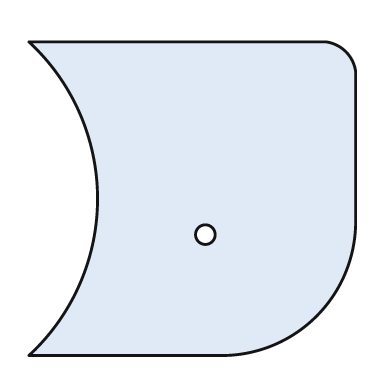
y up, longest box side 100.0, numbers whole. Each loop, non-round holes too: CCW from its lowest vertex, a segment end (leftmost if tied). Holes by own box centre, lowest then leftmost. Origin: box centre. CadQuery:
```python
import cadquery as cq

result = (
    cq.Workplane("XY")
    .moveTo(-50.0, -48.0)
    .lineTo(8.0, -48.0)
    .threePointArc((38.0, -36.0), (50.0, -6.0))
    .lineTo(50.0, 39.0)
    .threePointArc((47.0, 45.0), (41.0, 48.0))
    .lineTo(-50.0, 48.0)
    .threePointArc((-29.0, 0.0), (-50.0, -48.0))
    .close()
    .moveTo(4.0, -11.0)
    .circle(3.0)
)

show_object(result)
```